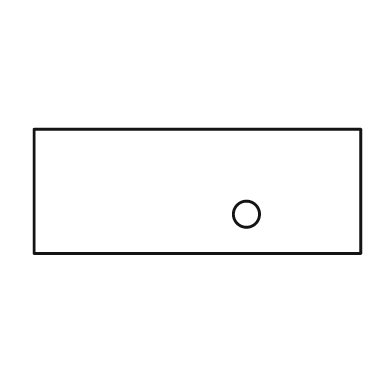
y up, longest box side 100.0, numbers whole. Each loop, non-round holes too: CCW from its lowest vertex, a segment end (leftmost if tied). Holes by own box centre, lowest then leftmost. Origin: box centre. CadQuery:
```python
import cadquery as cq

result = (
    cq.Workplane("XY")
    .moveTo(-50.0, -19.0)
    .lineTo(50.0, -19.0)
    .lineTo(50.0, 19.0)
    .lineTo(-50.0, 19.0)
    .close()
    .moveTo(15.0, -7.0)
    .circle(4.0)
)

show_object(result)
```